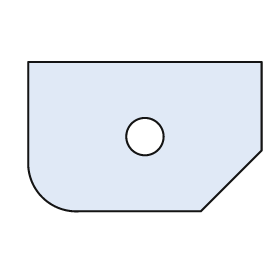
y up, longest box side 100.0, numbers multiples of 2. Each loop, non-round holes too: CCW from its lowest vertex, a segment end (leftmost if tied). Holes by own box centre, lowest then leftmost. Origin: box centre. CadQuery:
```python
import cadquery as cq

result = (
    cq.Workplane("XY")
    .moveTo(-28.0, -32.0)
    .lineTo(24.0, -32.0)
    .lineTo(50.0, -6.0)
    .lineTo(50.0, 32.0)
    .lineTo(-50.0, 32.0)
    .lineTo(-50.0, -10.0)
    .threePointArc((-44.0, -26.0), (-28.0, -32.0))
    .close()
    .moveTo(0.0, 0.0)
    .circle(8.0)
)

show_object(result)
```